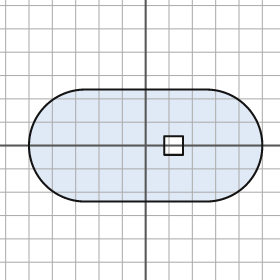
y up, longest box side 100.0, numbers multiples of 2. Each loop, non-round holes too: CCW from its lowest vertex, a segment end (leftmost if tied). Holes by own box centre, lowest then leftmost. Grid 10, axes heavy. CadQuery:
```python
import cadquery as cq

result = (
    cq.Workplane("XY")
    .moveTo(-26.0, -24.0)
    .lineTo(26.0, -24.0)
    .threePointArc((50.0, 0.0), (26.0, 24.0))
    .lineTo(-26.0, 24.0)
    .threePointArc((-50.0, 0.0), (-26.0, -24.0))
    .close()
    .moveTo(8.0, -4.0)
    .lineTo(16.0, -4.0)
    .lineTo(16.0, 4.0)
    .lineTo(8.0, 4.0)
    .close()
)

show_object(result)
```